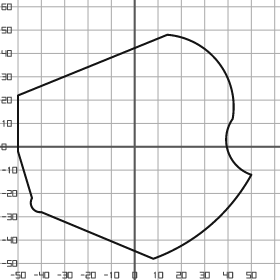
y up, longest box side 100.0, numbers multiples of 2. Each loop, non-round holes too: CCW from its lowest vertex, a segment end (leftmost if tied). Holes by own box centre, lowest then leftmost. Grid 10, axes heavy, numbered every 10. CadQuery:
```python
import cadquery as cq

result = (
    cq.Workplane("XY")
    .moveTo(8.0, -48.0)
    .threePointArc((32.0, -34.0), (50.0, -12.0))
    .threePointArc((40.0, -2.0), (42.0, 12.0))
    .threePointArc((36.0, 36.0), (14.0, 48.0))
    .lineTo(-50.0, 22.0)
    .lineTo(-50.0, -2.0)
    .lineTo(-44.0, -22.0)
    .threePointArc((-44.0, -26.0), (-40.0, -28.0))
    .close()
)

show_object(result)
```